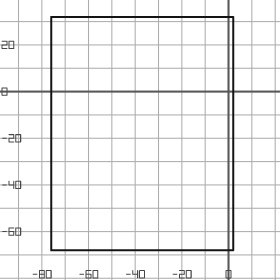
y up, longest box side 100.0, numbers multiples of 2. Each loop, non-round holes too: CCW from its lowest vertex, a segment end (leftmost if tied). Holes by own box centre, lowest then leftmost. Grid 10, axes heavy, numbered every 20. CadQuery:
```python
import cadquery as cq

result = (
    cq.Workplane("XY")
    .moveTo(-76.0, -68.0)
    .lineTo(2.0, -68.0)
    .lineTo(2.0, 32.0)
    .lineTo(-76.0, 32.0)
    .close()
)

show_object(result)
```